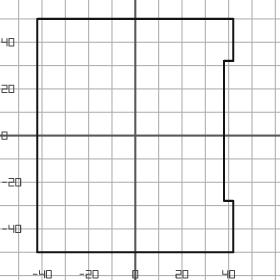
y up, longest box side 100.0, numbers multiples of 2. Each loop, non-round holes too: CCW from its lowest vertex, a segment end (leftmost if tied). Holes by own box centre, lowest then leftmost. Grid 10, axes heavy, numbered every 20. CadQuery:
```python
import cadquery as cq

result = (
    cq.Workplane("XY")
    .moveTo(-42.0, -50.0)
    .lineTo(42.0, -50.0)
    .lineTo(42.0, -28.0)
    .lineTo(38.0, -28.0)
    .lineTo(38.0, 32.0)
    .lineTo(42.0, 32.0)
    .lineTo(42.0, 50.0)
    .lineTo(-42.0, 50.0)
    .close()
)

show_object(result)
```